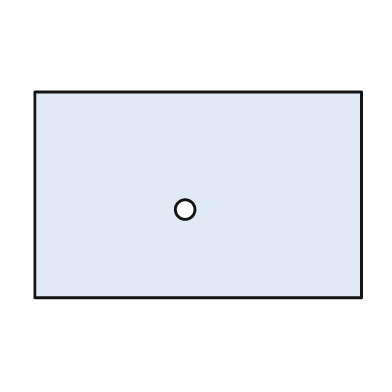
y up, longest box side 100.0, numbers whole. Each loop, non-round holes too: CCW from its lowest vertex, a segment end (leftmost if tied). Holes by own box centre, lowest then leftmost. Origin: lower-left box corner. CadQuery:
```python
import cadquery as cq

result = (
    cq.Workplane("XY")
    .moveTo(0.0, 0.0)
    .lineTo(100.0, 0.0)
    .lineTo(100.0, 63.0)
    .lineTo(0.0, 63.0)
    .close()
    .moveTo(46.0, 27.0)
    .circle(3.0)
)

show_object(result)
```